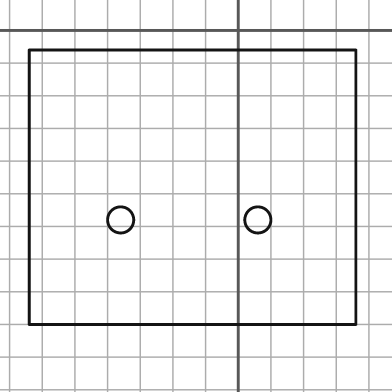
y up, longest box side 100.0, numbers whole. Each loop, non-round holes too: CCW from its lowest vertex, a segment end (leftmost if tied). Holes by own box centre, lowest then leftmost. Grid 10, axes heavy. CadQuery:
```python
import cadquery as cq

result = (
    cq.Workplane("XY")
    .moveTo(-64.0, -90.0)
    .lineTo(36.0, -90.0)
    .lineTo(36.0, -6.0)
    .lineTo(-64.0, -6.0)
    .close()
    .moveTo(-36.0, -58.0)
    .circle(4.0)
    .moveTo(6.0, -58.0)
    .circle(4.0)
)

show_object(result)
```